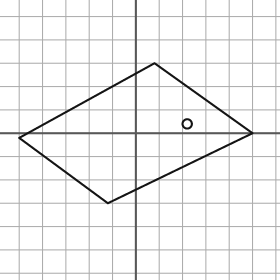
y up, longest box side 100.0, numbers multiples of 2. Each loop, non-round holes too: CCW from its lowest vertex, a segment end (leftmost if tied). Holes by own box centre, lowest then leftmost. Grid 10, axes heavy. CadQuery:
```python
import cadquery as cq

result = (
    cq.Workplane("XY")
    .moveTo(-12.0, -30.0)
    .lineTo(50.0, 0.0)
    .lineTo(8.0, 30.0)
    .lineTo(-50.0, -2.0)
    .close()
    .moveTo(22.0, 4.0)
    .circle(2.0)
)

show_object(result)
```